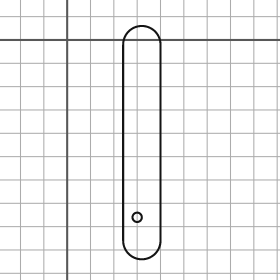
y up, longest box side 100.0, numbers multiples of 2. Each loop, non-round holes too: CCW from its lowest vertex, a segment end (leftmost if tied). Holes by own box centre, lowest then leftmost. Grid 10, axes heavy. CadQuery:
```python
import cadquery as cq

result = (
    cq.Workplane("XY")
    .moveTo(24.0, -86.0)
    .threePointArc((32.0, -94.0), (40.0, -86.0))
    .lineTo(40.0, -2.0)
    .threePointArc((32.0, 6.0), (24.0, -2.0))
    .close()
    .moveTo(30.0, -76.0)
    .circle(2.0)
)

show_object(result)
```